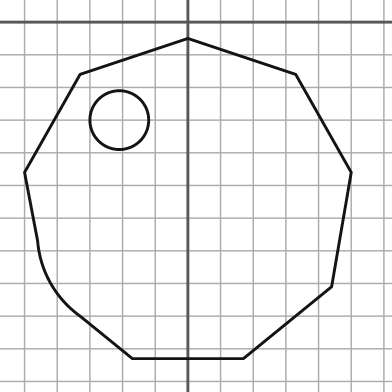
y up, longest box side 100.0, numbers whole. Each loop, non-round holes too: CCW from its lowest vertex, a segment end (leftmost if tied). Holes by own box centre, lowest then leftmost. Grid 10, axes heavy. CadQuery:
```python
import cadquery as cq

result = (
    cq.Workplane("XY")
    .moveTo(-17.0, -103.0)
    .lineTo(17.0, -103.0)
    .lineTo(44.0, -81.0)
    .lineTo(50.0, -46.0)
    .lineTo(33.0, -16.0)
    .lineTo(0.0, -5.0)
    .lineTo(-33.0, -16.0)
    .lineTo(-50.0, -46.0)
    .lineTo(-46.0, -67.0)
    .threePointArc((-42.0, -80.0), (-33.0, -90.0))
    .close()
    .moveTo(-21.0, -30.0)
    .circle(9.0)
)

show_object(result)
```